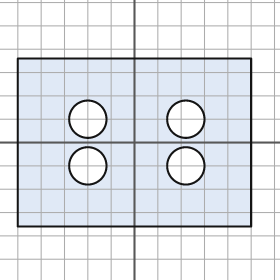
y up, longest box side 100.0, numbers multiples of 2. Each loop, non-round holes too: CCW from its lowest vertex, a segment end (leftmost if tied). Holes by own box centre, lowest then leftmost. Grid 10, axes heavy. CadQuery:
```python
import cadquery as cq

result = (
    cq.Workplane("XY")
    .moveTo(-50.0, -36.0)
    .lineTo(50.0, -36.0)
    .lineTo(50.0, 36.0)
    .lineTo(-50.0, 36.0)
    .close()
    .moveTo(-20.0, -10.0)
    .circle(8.0)
    .moveTo(22.0, -10.0)
    .circle(8.0)
    .moveTo(-20.0, 10.0)
    .circle(8.0)
    .moveTo(22.0, 10.0)
    .circle(8.0)
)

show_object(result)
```